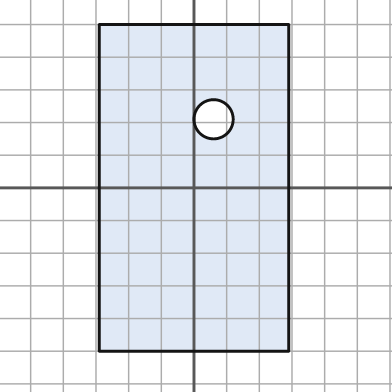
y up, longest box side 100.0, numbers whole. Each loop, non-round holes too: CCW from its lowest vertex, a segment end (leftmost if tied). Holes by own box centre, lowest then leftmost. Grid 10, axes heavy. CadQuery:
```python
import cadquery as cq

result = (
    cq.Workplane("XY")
    .moveTo(-29.0, -50.0)
    .lineTo(29.0, -50.0)
    .lineTo(29.0, 50.0)
    .lineTo(-29.0, 50.0)
    .close()
    .moveTo(6.0, 21.0)
    .circle(6.0)
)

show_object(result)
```